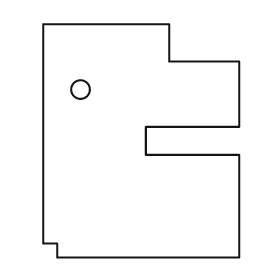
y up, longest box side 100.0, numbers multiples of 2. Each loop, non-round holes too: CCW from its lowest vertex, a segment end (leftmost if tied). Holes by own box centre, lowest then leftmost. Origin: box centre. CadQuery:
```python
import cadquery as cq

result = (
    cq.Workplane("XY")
    .moveTo(-36.0, -50.0)
    .lineTo(42.0, -50.0)
    .lineTo(42.0, -6.0)
    .lineTo(2.0, -6.0)
    .lineTo(2.0, 6.0)
    .lineTo(42.0, 6.0)
    .lineTo(42.0, 34.0)
    .lineTo(12.0, 34.0)
    .lineTo(12.0, 50.0)
    .lineTo(-42.0, 50.0)
    .lineTo(-42.0, -44.0)
    .lineTo(-36.0, -44.0)
    .close()
    .moveTo(-26.0, 22.0)
    .circle(4.0)
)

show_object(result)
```